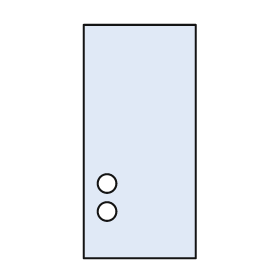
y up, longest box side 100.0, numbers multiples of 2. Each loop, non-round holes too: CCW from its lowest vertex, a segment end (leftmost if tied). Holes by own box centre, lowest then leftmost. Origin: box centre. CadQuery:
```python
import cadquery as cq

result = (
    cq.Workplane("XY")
    .moveTo(-24.0, -50.0)
    .lineTo(24.0, -50.0)
    .lineTo(24.0, 50.0)
    .lineTo(-24.0, 50.0)
    .close()
    .moveTo(-14.0, -30.0)
    .circle(4.0)
    .moveTo(-14.0, -18.0)
    .circle(4.0)
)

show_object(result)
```